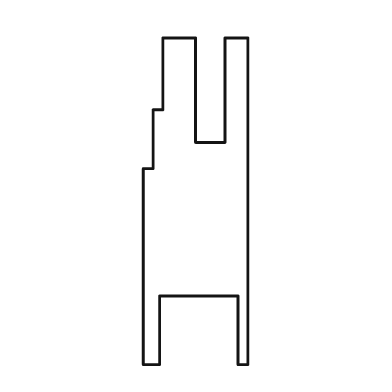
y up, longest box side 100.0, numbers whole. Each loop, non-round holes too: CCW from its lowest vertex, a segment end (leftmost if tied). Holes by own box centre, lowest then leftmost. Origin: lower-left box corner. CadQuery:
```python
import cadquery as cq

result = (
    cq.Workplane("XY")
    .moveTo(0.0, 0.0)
    .lineTo(5.0, 0.0)
    .lineTo(5.0, 21.0)
    .lineTo(29.0, 21.0)
    .lineTo(29.0, 0.0)
    .lineTo(32.0, 0.0)
    .lineTo(32.0, 100.0)
    .lineTo(25.0, 100.0)
    .lineTo(25.0, 68.0)
    .lineTo(16.0, 68.0)
    .lineTo(16.0, 100.0)
    .lineTo(6.0, 100.0)
    .lineTo(6.0, 78.0)
    .lineTo(3.0, 78.0)
    .lineTo(3.0, 60.0)
    .lineTo(0.0, 60.0)
    .close()
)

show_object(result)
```